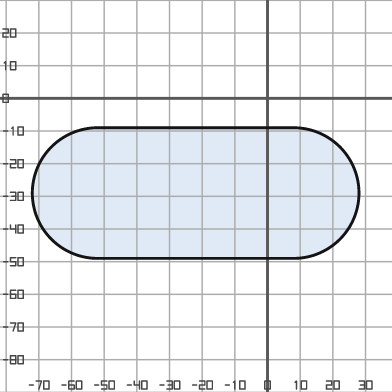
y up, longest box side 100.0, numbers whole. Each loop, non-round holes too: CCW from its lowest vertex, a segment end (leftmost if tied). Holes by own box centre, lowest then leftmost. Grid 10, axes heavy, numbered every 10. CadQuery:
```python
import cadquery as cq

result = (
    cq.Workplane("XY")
    .moveTo(-52.0, -49.0)
    .lineTo(8.0, -49.0)
    .threePointArc((28.0, -29.0), (8.0, -9.0))
    .lineTo(-52.0, -9.0)
    .threePointArc((-72.0, -29.0), (-52.0, -49.0))
    .close()
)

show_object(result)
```